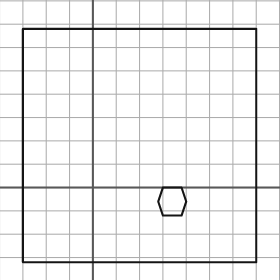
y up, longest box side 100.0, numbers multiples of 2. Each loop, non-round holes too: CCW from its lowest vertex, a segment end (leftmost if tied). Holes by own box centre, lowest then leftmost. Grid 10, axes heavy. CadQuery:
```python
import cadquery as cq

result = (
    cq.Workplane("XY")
    .moveTo(-30.0, -32.0)
    .lineTo(70.0, -32.0)
    .lineTo(70.0, 68.0)
    .lineTo(-30.0, 68.0)
    .close()
    .moveTo(30.0, -12.0)
    .lineTo(38.0, -12.0)
    .lineTo(40.0, -6.0)
    .lineTo(38.0, 0.0)
    .lineTo(30.0, 0.0)
    .lineTo(28.0, -6.0)
    .close()
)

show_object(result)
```